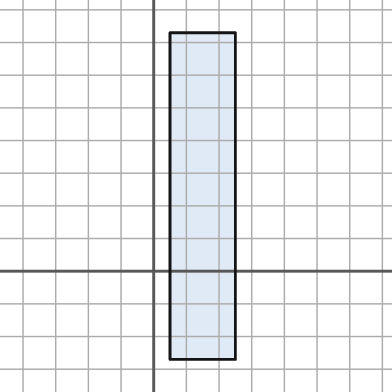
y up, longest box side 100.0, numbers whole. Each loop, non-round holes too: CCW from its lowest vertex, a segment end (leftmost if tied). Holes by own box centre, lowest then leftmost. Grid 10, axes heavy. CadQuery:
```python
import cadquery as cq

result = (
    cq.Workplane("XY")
    .moveTo(5.0, -27.0)
    .lineTo(25.0, -27.0)
    .lineTo(25.0, 73.0)
    .lineTo(5.0, 73.0)
    .close()
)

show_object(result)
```